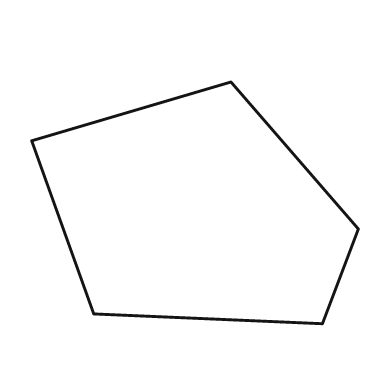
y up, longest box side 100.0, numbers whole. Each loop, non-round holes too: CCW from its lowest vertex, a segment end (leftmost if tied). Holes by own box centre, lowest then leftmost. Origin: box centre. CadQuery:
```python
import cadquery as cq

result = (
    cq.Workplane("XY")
    .moveTo(39.0, -37.0)
    .lineTo(50.0, -8.0)
    .lineTo(11.0, 37.0)
    .lineTo(-50.0, 19.0)
    .lineTo(-31.0, -34.0)
    .close()
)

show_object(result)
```